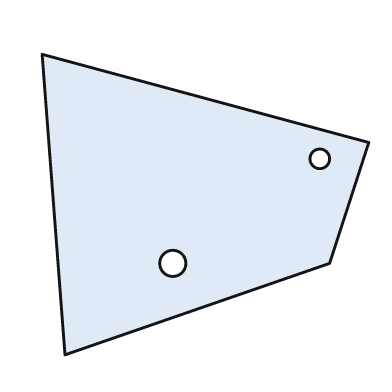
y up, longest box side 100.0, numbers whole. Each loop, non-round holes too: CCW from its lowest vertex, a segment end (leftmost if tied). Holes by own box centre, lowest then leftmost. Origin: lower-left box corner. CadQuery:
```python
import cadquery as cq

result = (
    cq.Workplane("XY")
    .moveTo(7.0, 0.0)
    .lineTo(88.0, 28.0)
    .lineTo(100.0, 65.0)
    .lineTo(0.0, 92.0)
    .close()
    .moveTo(40.0, 28.0)
    .circle(4.0)
    .moveTo(85.0, 60.0)
    .circle(3.0)
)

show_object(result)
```